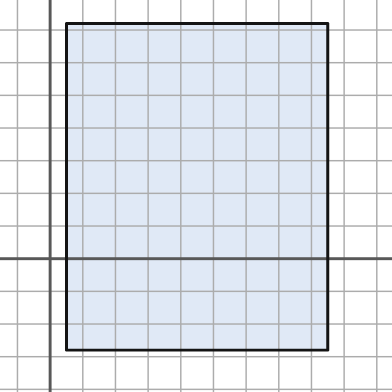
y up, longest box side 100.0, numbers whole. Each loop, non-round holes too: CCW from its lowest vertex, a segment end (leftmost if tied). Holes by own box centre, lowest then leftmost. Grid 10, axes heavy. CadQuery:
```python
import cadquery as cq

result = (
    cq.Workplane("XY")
    .moveTo(5.0, -28.0)
    .lineTo(85.0, -28.0)
    .lineTo(85.0, 72.0)
    .lineTo(5.0, 72.0)
    .close()
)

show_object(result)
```